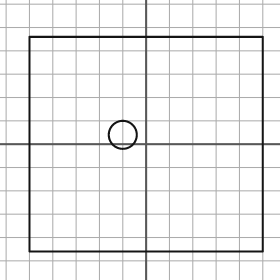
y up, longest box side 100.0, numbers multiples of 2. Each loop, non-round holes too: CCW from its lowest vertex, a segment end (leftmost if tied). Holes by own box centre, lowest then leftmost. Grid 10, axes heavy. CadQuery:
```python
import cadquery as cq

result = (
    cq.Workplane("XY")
    .moveTo(-50.0, -46.0)
    .lineTo(50.0, -46.0)
    .lineTo(50.0, 46.0)
    .lineTo(-50.0, 46.0)
    .close()
    .moveTo(-10.0, 4.0)
    .circle(6.0)
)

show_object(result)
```